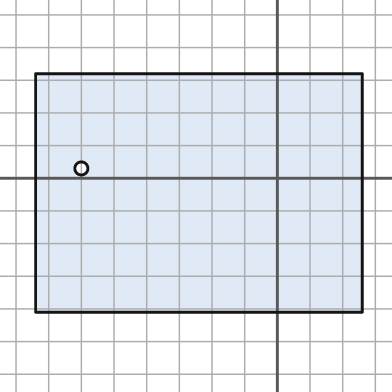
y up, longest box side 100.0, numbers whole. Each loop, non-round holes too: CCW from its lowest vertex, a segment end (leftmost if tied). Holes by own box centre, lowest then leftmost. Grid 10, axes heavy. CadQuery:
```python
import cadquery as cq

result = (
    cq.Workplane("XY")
    .moveTo(-74.0, -41.0)
    .lineTo(26.0, -41.0)
    .lineTo(26.0, 32.0)
    .lineTo(-74.0, 32.0)
    .close()
    .moveTo(-60.0, 3.0)
    .circle(2.0)
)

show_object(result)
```